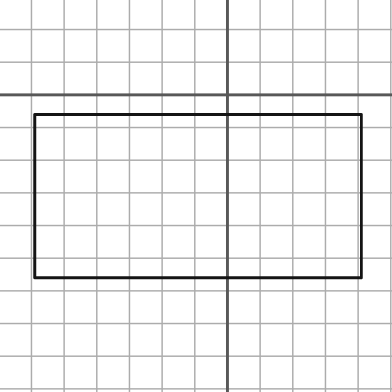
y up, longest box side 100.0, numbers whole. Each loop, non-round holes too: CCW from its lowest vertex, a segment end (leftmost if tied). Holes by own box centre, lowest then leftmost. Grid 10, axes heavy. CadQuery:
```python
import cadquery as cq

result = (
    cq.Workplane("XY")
    .moveTo(-59.0, -56.0)
    .lineTo(41.0, -56.0)
    .lineTo(41.0, -6.0)
    .lineTo(-59.0, -6.0)
    .close()
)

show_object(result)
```